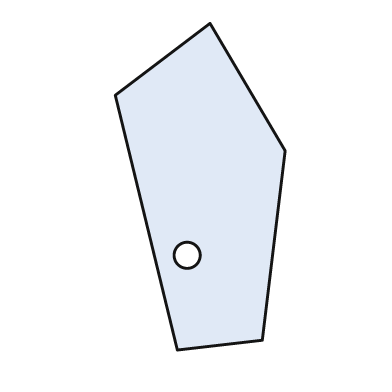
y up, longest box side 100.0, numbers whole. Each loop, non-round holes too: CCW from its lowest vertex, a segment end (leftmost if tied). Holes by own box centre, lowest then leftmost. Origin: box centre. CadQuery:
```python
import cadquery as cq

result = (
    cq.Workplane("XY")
    .moveTo(-7.0, -50.0)
    .lineTo(19.0, -47.0)
    .lineTo(26.0, 11.0)
    .lineTo(3.0, 50.0)
    .lineTo(-26.0, 28.0)
    .close()
    .moveTo(-4.0, -21.0)
    .circle(4.0)
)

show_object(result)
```